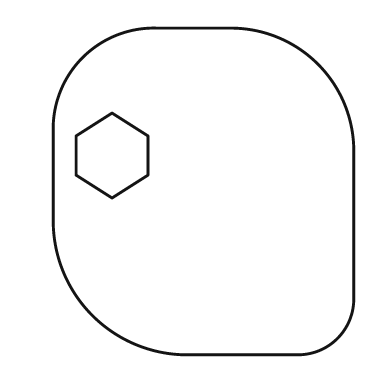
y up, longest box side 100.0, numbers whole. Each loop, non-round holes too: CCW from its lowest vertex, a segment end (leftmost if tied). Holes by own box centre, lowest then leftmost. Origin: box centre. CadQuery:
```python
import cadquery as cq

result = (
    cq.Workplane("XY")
    .moveTo(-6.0, -50.0)
    .lineTo(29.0, -50.0)
    .threePointArc((41.0, -45.0), (46.0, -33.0))
    .lineTo(46.0, 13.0)
    .threePointArc((35.0, 39.0), (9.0, 50.0))
    .lineTo(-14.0, 50.0)
    .threePointArc((-37.0, 41.0), (-46.0, 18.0))
    .lineTo(-46.0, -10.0)
    .threePointArc((-34.0, -38.0), (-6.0, -50.0))
    .close()
    .moveTo(-28.0, -2.0)
    .lineTo(-17.0, 5.0)
    .lineTo(-17.0, 17.0)
    .lineTo(-28.0, 24.0)
    .lineTo(-39.0, 17.0)
    .lineTo(-39.0, 5.0)
    .close()
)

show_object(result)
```